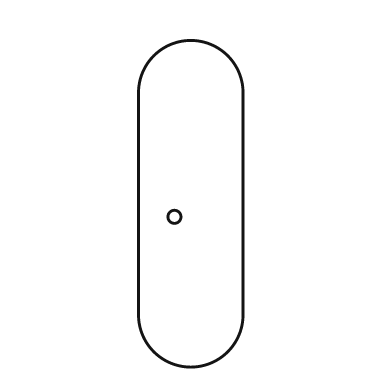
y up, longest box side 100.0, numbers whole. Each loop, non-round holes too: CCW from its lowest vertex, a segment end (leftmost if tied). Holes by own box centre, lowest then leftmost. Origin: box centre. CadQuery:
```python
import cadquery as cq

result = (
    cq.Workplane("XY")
    .moveTo(-16.0, -34.0)
    .threePointArc((0.0, -50.0), (16.0, -34.0))
    .lineTo(16.0, 34.0)
    .threePointArc((0.0, 50.0), (-16.0, 34.0))
    .close()
    .moveTo(-5.0, -4.0)
    .circle(2.0)
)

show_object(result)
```